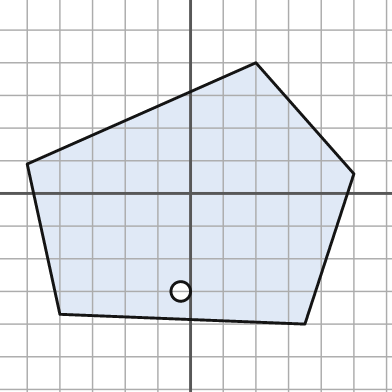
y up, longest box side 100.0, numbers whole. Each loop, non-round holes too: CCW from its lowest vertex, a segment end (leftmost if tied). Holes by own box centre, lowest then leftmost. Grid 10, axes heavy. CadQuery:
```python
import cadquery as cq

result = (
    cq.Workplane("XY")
    .moveTo(35.0, -40.0)
    .lineTo(50.0, 6.0)
    .lineTo(20.0, 40.0)
    .lineTo(-50.0, 9.0)
    .lineTo(-40.0, -37.0)
    .close()
    .moveTo(-3.0, -30.0)
    .circle(3.0)
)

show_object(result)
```